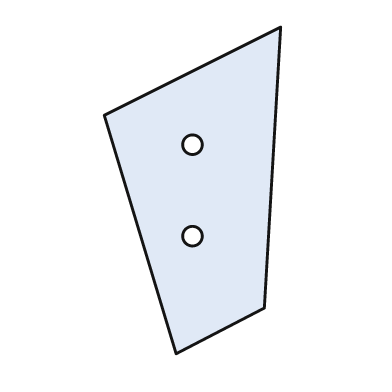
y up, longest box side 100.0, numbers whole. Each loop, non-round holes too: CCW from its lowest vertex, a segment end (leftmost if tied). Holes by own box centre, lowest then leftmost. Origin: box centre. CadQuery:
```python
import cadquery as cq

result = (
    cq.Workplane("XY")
    .moveTo(-5.0, -50.0)
    .lineTo(22.0, -36.0)
    .lineTo(27.0, 50.0)
    .lineTo(-27.0, 23.0)
    .close()
    .moveTo(0.0, -14.0)
    .circle(3.0)
    .moveTo(0.0, 14.0)
    .circle(3.0)
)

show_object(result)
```